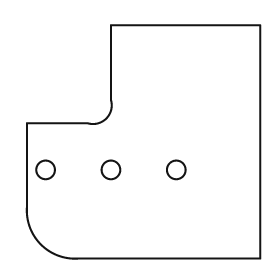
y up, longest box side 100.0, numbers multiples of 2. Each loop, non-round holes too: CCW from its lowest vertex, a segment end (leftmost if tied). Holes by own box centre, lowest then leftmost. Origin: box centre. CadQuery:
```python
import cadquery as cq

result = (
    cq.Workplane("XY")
    .moveTo(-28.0, -50.0)
    .lineTo(50.0, -50.0)
    .lineTo(50.0, 50.0)
    .lineTo(-14.0, 50.0)
    .lineTo(-14.0, 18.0)
    .threePointArc((-16.0, 10.0), (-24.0, 8.0))
    .lineTo(-50.0, 8.0)
    .lineTo(-50.0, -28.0)
    .threePointArc((-44.0, -44.0), (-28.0, -50.0))
    .close()
    .moveTo(-42.0, -12.0)
    .circle(4.0)
    .moveTo(-14.0, -12.0)
    .circle(4.0)
    .moveTo(14.0, -12.0)
    .circle(4.0)
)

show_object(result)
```